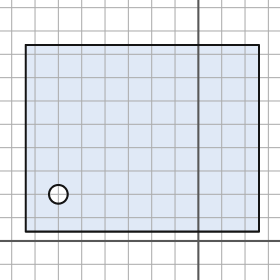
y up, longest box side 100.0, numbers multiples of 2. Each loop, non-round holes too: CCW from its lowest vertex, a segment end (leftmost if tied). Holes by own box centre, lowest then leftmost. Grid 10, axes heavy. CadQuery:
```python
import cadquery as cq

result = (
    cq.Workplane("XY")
    .moveTo(-74.0, 4.0)
    .lineTo(26.0, 4.0)
    .lineTo(26.0, 84.0)
    .lineTo(-74.0, 84.0)
    .close()
    .moveTo(-60.0, 20.0)
    .circle(4.0)
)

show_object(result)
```